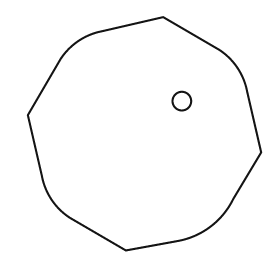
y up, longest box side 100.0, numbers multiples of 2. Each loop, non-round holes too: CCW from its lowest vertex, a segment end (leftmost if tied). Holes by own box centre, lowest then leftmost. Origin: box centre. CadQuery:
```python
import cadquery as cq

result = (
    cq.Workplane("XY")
    .moveTo(-8.0, -50.0)
    .lineTo(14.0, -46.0)
    .threePointArc((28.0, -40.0), (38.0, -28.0))
    .lineTo(50.0, -8.0)
    .lineTo(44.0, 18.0)
    .threePointArc((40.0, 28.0), (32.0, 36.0))
    .lineTo(8.0, 50.0)
    .lineTo(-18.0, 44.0)
    .threePointArc((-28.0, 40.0), (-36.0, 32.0))
    .lineTo(-50.0, 8.0)
    .lineTo(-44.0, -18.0)
    .threePointArc((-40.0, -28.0), (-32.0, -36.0))
    .close()
    .moveTo(16.0, 14.0)
    .circle(4.0)
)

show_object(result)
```